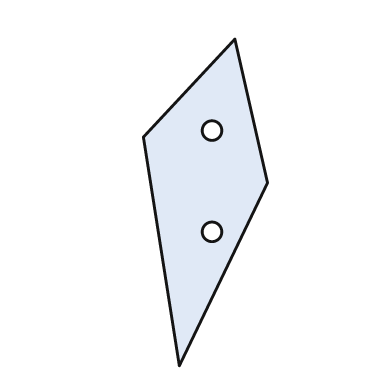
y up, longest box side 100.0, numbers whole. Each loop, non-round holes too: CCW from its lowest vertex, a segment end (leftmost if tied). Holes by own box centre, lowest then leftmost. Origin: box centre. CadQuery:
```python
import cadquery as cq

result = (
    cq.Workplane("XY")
    .moveTo(-8.0, -50.0)
    .lineTo(19.0, 6.0)
    .lineTo(9.0, 50.0)
    .lineTo(-19.0, 20.0)
    .close()
    .moveTo(2.0, -9.0)
    .circle(3.0)
    .moveTo(2.0, 22.0)
    .circle(3.0)
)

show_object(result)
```